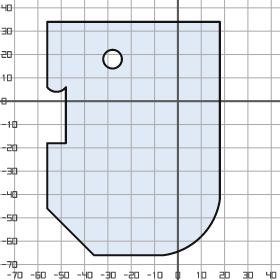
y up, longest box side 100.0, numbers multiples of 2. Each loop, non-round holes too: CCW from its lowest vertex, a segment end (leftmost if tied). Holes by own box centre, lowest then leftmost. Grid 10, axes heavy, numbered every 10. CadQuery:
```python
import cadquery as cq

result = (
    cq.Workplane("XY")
    .moveTo(-36.0, -66.0)
    .lineTo(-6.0, -66.0)
    .threePointArc((10.0, -58.0), (18.0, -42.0))
    .lineTo(18.0, 34.0)
    .lineTo(-56.0, 34.0)
    .lineTo(-56.0, 6.0)
    .threePointArc((-52.0, 4.0), (-48.0, 6.0))
    .lineTo(-48.0, -18.0)
    .lineTo(-56.0, -18.0)
    .lineTo(-56.0, -46.0)
    .close()
    .moveTo(-28.0, 18.0)
    .circle(4.0)
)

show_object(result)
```